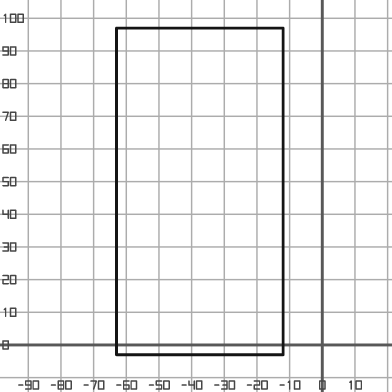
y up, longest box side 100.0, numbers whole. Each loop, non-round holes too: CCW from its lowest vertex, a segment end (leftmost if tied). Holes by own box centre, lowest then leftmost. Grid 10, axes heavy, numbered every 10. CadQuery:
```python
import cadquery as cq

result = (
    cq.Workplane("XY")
    .moveTo(-63.0, -3.0)
    .lineTo(-12.0, -3.0)
    .lineTo(-12.0, 97.0)
    .lineTo(-63.0, 97.0)
    .close()
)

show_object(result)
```